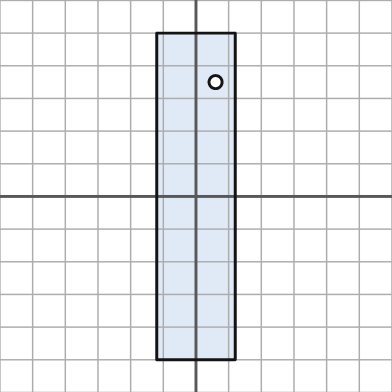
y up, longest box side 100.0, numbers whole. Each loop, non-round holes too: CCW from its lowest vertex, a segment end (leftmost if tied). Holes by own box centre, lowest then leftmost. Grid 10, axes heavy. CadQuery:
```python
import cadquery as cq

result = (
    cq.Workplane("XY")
    .moveTo(-12.0, -50.0)
    .lineTo(12.0, -50.0)
    .lineTo(12.0, 50.0)
    .lineTo(-12.0, 50.0)
    .close()
    .moveTo(6.0, 35.0)
    .circle(2.0)
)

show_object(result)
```